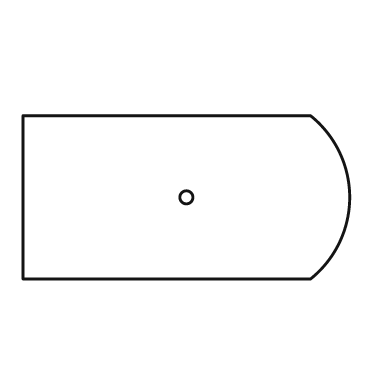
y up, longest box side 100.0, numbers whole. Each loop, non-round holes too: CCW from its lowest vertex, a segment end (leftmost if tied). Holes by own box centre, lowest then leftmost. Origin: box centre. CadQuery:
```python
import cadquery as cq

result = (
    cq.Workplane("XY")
    .moveTo(-50.0, -25.0)
    .lineTo(38.0, -25.0)
    .threePointArc((50.0, 0.0), (38.0, 25.0))
    .lineTo(-50.0, 25.0)
    .close()
    .moveTo(0.0, 0.0)
    .circle(2.0)
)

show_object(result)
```